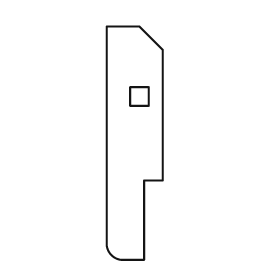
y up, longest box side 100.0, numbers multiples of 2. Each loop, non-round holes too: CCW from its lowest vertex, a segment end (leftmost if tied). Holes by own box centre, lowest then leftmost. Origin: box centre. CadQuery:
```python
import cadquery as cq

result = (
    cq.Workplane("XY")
    .moveTo(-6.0, -50.0)
    .lineTo(4.0, -50.0)
    .lineTo(4.0, -16.0)
    .lineTo(12.0, -16.0)
    .lineTo(12.0, 40.0)
    .lineTo(2.0, 50.0)
    .lineTo(-12.0, 50.0)
    .lineTo(-12.0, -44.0)
    .threePointArc((-10.0, -48.0), (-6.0, -50.0))
    .close()
    .moveTo(-2.0, 16.0)
    .lineTo(6.0, 16.0)
    .lineTo(6.0, 24.0)
    .lineTo(-2.0, 24.0)
    .close()
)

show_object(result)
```